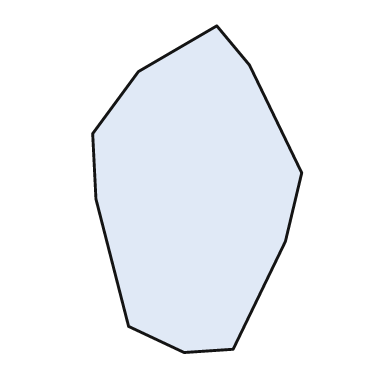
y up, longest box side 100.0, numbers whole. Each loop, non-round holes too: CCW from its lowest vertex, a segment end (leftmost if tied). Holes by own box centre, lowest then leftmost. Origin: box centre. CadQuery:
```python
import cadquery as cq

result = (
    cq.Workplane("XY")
    .moveTo(-4.0, -50.0)
    .lineTo(11.0, -49.0)
    .lineTo(27.0, -16.0)
    .lineTo(32.0, 5.0)
    .lineTo(16.0, 38.0)
    .lineTo(6.0, 50.0)
    .lineTo(-18.0, 36.0)
    .lineTo(-32.0, 17.0)
    .lineTo(-31.0, -3.0)
    .lineTo(-21.0, -42.0)
    .close()
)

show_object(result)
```